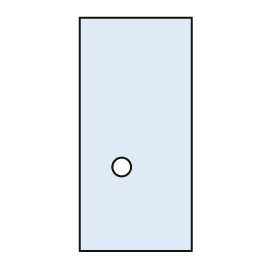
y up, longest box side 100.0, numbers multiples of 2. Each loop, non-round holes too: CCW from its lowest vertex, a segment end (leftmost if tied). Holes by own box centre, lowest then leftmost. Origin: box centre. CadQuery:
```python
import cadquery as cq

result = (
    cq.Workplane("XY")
    .moveTo(-24.0, -50.0)
    .lineTo(24.0, -50.0)
    .lineTo(24.0, 50.0)
    .lineTo(-24.0, 50.0)
    .close()
    .moveTo(-6.0, -14.0)
    .circle(4.0)
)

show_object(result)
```